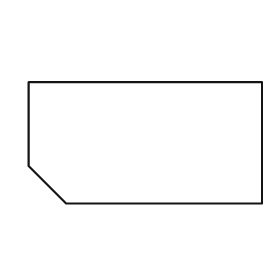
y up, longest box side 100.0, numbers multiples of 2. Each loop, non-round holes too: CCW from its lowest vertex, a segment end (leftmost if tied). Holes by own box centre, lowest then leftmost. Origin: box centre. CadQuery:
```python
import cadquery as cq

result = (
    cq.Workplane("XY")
    .moveTo(-34.0, -26.0)
    .lineTo(50.0, -26.0)
    .lineTo(50.0, 26.0)
    .lineTo(-50.0, 26.0)
    .lineTo(-50.0, -10.0)
    .close()
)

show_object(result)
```